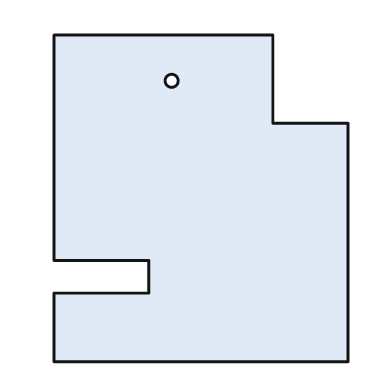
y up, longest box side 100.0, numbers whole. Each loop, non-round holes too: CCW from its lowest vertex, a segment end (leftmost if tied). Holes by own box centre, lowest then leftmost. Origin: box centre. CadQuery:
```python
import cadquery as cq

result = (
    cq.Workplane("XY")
    .moveTo(-45.0, -50.0)
    .lineTo(45.0, -50.0)
    .lineTo(45.0, 23.0)
    .lineTo(22.0, 23.0)
    .lineTo(22.0, 50.0)
    .lineTo(-45.0, 50.0)
    .lineTo(-45.0, -19.0)
    .lineTo(-16.0, -19.0)
    .lineTo(-16.0, -29.0)
    .lineTo(-45.0, -29.0)
    .close()
    .moveTo(-9.0, 36.0)
    .circle(2.0)
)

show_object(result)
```